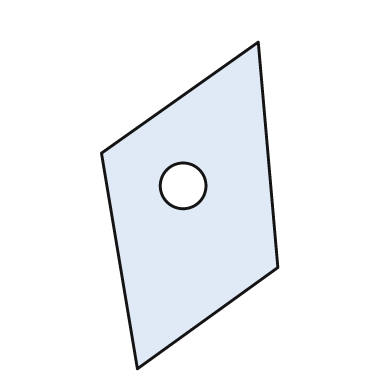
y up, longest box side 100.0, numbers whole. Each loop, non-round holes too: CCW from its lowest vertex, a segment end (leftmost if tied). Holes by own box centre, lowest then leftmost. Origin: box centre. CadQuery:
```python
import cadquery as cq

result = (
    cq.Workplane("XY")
    .moveTo(-16.0, -50.0)
    .lineTo(27.0, -19.0)
    .lineTo(21.0, 50.0)
    .lineTo(-27.0, 16.0)
    .close()
    .moveTo(-2.0, 6.0)
    .circle(7.0)
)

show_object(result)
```